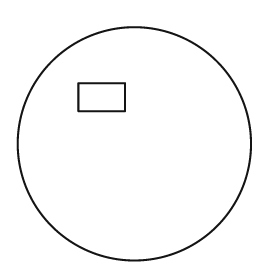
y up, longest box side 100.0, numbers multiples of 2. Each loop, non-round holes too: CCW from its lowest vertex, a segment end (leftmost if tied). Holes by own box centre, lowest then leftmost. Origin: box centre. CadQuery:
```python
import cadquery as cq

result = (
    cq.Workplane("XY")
    .moveTo(0.0, 0.0)
    .circle(50.0)
    .moveTo(-24.0, 14.0)
    .lineTo(-4.0, 14.0)
    .lineTo(-4.0, 26.0)
    .lineTo(-24.0, 26.0)
    .close()
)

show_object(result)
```